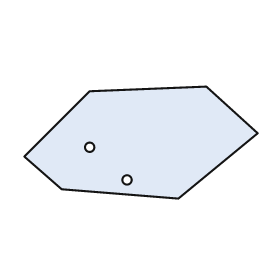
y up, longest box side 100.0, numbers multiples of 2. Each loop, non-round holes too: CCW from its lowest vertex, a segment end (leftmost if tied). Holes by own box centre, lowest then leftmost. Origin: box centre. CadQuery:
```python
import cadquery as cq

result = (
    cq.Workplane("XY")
    .moveTo(16.0, -24.0)
    .lineTo(50.0, 4.0)
    .lineTo(28.0, 24.0)
    .lineTo(-22.0, 22.0)
    .lineTo(-50.0, -6.0)
    .lineTo(-34.0, -20.0)
    .close()
    .moveTo(-6.0, -16.0)
    .circle(2.0)
    .moveTo(-22.0, -2.0)
    .circle(2.0)
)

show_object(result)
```